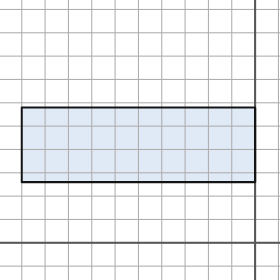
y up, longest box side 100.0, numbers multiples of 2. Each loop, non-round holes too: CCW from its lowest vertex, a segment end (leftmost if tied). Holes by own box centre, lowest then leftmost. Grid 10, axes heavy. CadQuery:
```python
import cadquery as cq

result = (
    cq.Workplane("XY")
    .moveTo(-100.0, 26.0)
    .lineTo(0.0, 26.0)
    .lineTo(0.0, 58.0)
    .lineTo(-100.0, 58.0)
    .close()
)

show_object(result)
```